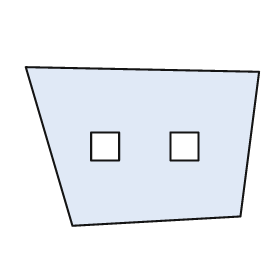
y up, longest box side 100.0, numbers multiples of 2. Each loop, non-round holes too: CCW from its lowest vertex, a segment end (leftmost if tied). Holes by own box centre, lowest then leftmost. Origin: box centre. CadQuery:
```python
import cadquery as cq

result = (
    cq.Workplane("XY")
    .moveTo(-30.0, -34.0)
    .lineTo(42.0, -30.0)
    .lineTo(50.0, 32.0)
    .lineTo(-50.0, 34.0)
    .close()
    .moveTo(-22.0, -6.0)
    .lineTo(-10.0, -6.0)
    .lineTo(-10.0, 6.0)
    .lineTo(-22.0, 6.0)
    .close()
    .moveTo(12.0, -6.0)
    .lineTo(24.0, -6.0)
    .lineTo(24.0, 6.0)
    .lineTo(12.0, 6.0)
    .close()
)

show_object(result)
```